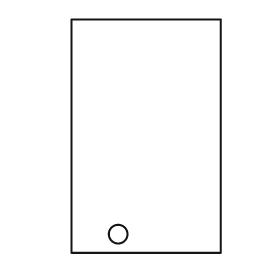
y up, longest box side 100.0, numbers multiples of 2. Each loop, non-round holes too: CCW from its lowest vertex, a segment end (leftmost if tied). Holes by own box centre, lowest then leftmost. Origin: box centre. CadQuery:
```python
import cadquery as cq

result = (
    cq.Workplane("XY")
    .moveTo(-32.0, -50.0)
    .lineTo(32.0, -50.0)
    .lineTo(32.0, 50.0)
    .lineTo(-32.0, 50.0)
    .close()
    .moveTo(-12.0, -42.0)
    .circle(4.0)
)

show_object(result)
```